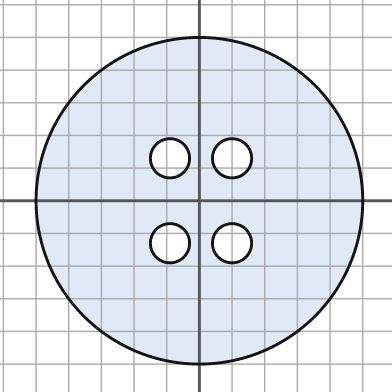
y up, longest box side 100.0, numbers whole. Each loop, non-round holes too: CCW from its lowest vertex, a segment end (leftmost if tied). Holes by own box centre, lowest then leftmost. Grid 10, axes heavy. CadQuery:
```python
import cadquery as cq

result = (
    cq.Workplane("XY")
    .moveTo(0.0, 0.0)
    .circle(50.0)
    .moveTo(-9.0, -13.0)
    .circle(6.0)
    .moveTo(10.0, -13.0)
    .circle(6.0)
    .moveTo(-9.0, 13.0)
    .circle(6.0)
    .moveTo(10.0, 13.0)
    .circle(6.0)
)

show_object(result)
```